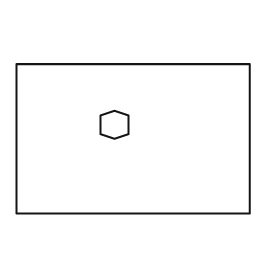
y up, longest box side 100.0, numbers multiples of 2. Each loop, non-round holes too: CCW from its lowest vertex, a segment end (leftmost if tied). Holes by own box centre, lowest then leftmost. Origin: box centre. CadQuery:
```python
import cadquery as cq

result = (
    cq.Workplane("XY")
    .moveTo(-50.0, -32.0)
    .lineTo(50.0, -32.0)
    .lineTo(50.0, 32.0)
    .lineTo(-50.0, 32.0)
    .close()
    .moveTo(-8.0, 0.0)
    .lineTo(-2.0, 2.0)
    .lineTo(-2.0, 10.0)
    .lineTo(-8.0, 12.0)
    .lineTo(-14.0, 10.0)
    .lineTo(-14.0, 2.0)
    .close()
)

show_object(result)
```